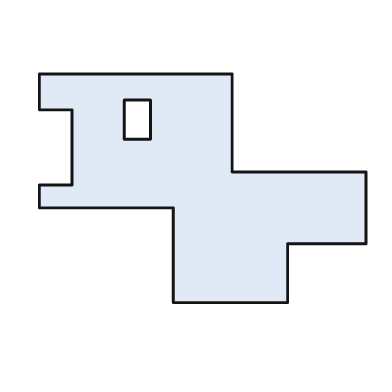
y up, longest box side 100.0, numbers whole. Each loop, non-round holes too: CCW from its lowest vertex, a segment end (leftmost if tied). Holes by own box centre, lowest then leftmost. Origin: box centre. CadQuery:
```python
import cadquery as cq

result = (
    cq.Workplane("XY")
    .moveTo(-9.0, -35.0)
    .lineTo(26.0, -35.0)
    .lineTo(26.0, -17.0)
    .lineTo(50.0, -17.0)
    .lineTo(50.0, 5.0)
    .lineTo(9.0, 5.0)
    .lineTo(9.0, 35.0)
    .lineTo(-50.0, 35.0)
    .lineTo(-50.0, 24.0)
    .lineTo(-40.0, 24.0)
    .lineTo(-40.0, 1.0)
    .lineTo(-50.0, 1.0)
    .lineTo(-50.0, -6.0)
    .lineTo(-9.0, -6.0)
    .close()
    .moveTo(-24.0, 15.0)
    .lineTo(-16.0, 15.0)
    .lineTo(-16.0, 27.0)
    .lineTo(-24.0, 27.0)
    .close()
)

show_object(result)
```